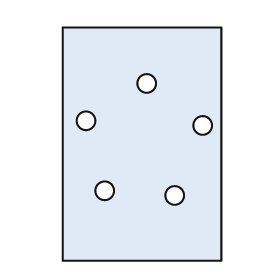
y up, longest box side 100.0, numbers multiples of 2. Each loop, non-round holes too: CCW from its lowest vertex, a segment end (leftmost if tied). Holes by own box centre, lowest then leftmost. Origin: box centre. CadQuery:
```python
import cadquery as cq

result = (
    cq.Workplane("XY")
    .moveTo(-34.0, -50.0)
    .lineTo(34.0, -50.0)
    .lineTo(34.0, 50.0)
    .lineTo(-34.0, 50.0)
    .close()
    .moveTo(14.0, -22.0)
    .circle(4.0)
    .moveTo(-16.0, -20.0)
    .circle(4.0)
    .moveTo(26.0, 8.0)
    .circle(4.0)
    .moveTo(-24.0, 10.0)
    .circle(4.0)
    .moveTo(2.0, 26.0)
    .circle(4.0)
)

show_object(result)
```